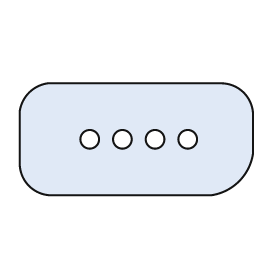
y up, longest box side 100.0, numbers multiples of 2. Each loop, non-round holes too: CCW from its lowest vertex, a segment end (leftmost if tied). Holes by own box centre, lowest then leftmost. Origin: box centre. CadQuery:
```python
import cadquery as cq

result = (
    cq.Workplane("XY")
    .moveTo(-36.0, -24.0)
    .lineTo(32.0, -24.0)
    .threePointArc((44.0, -18.0), (50.0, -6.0))
    .lineTo(50.0, 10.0)
    .threePointArc((46.0, 20.0), (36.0, 24.0))
    .lineTo(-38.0, 24.0)
    .threePointArc((-46.0, 20.0), (-50.0, 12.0))
    .lineTo(-50.0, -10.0)
    .threePointArc((-46.0, -20.0), (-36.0, -24.0))
    .close()
    .moveTo(-20.0, 0.0)
    .circle(4.0)
    .moveTo(-6.0, 0.0)
    .circle(4.0)
    .moveTo(8.0, 0.0)
    .circle(4.0)
    .moveTo(22.0, 0.0)
    .circle(4.0)
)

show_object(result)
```